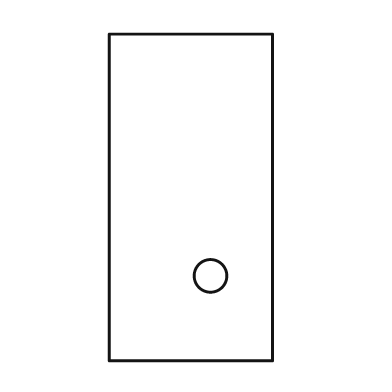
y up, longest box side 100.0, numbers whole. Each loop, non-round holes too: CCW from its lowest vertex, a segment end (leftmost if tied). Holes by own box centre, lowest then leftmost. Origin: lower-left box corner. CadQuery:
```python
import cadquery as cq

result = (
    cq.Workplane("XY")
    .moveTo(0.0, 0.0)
    .lineTo(50.0, 0.0)
    .lineTo(50.0, 100.0)
    .lineTo(0.0, 100.0)
    .close()
    .moveTo(31.0, 26.0)
    .circle(5.0)
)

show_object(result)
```